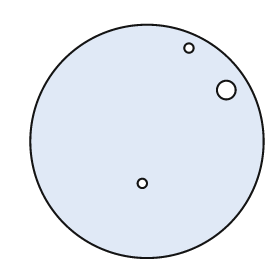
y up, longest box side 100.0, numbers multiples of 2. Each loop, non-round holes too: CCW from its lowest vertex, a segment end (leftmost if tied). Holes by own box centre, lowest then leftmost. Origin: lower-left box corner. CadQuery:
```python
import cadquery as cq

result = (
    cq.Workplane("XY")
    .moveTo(50.0, 50.0)
    .circle(50.0)
    .moveTo(48.0, 32.0)
    .circle(2.0)
    .moveTo(84.0, 72.0)
    .circle(4.0)
    .moveTo(68.0, 90.0)
    .circle(2.0)
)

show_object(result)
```